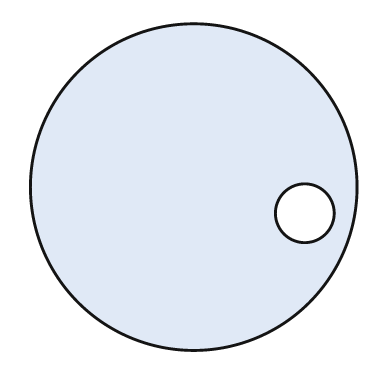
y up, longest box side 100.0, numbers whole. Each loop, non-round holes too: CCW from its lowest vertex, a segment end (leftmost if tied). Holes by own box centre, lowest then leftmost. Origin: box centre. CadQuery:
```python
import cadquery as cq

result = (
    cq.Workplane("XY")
    .moveTo(0.0, 0.0)
    .circle(50.0)
    .moveTo(34.0, -8.0)
    .circle(9.0)
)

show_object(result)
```